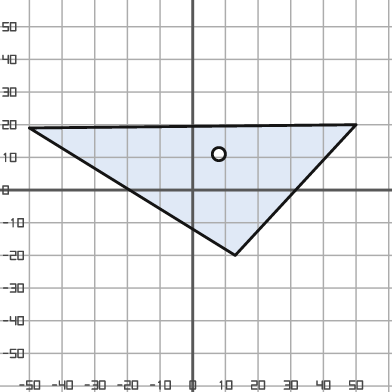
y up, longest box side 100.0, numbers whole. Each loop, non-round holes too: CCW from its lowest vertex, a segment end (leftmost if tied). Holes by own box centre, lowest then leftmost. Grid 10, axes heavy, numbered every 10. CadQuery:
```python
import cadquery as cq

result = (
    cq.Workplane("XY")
    .moveTo(13.0, -20.0)
    .lineTo(50.0, 20.0)
    .lineTo(-50.0, 19.0)
    .close()
    .moveTo(8.0, 11.0)
    .circle(2.0)
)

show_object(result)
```